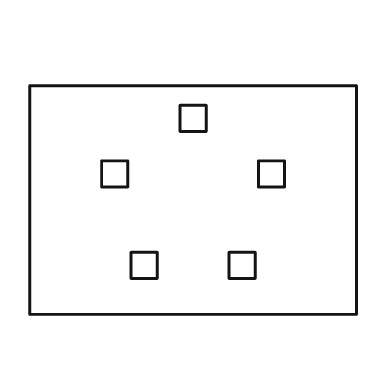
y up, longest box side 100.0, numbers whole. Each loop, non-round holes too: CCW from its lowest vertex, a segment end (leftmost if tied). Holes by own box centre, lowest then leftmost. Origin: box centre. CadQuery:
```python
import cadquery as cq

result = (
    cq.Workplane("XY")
    .moveTo(-50.0, -35.0)
    .lineTo(50.0, -35.0)
    .lineTo(50.0, 35.0)
    .lineTo(-50.0, 35.0)
    .close()
    .moveTo(-19.0, -24.0)
    .lineTo(-11.0, -24.0)
    .lineTo(-11.0, -16.0)
    .lineTo(-19.0, -16.0)
    .close()
    .moveTo(11.0, -24.0)
    .lineTo(19.0, -24.0)
    .lineTo(19.0, -16.0)
    .lineTo(11.0, -16.0)
    .close()
    .moveTo(-28.0, 4.0)
    .lineTo(-20.0, 4.0)
    .lineTo(-20.0, 12.0)
    .lineTo(-28.0, 12.0)
    .close()
    .moveTo(20.0, 4.0)
    .lineTo(28.0, 4.0)
    .lineTo(28.0, 12.0)
    .lineTo(20.0, 12.0)
    .close()
    .moveTo(-4.0, 21.0)
    .lineTo(4.0, 21.0)
    .lineTo(4.0, 29.0)
    .lineTo(-4.0, 29.0)
    .close()
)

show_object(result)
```